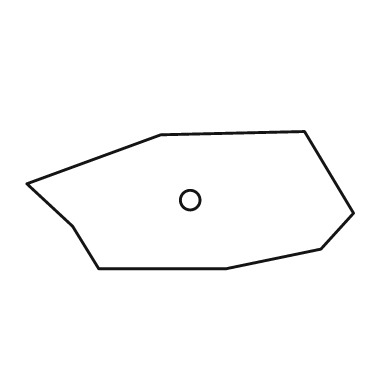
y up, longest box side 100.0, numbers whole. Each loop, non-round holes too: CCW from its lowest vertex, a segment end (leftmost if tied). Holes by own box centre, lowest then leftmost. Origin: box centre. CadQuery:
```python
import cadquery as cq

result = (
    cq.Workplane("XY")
    .moveTo(-28.0, -21.0)
    .lineTo(11.0, -21.0)
    .lineTo(40.0, -15.0)
    .lineTo(50.0, -4.0)
    .lineTo(35.0, 21.0)
    .lineTo(-9.0, 20.0)
    .lineTo(-50.0, 5.0)
    .lineTo(-36.0, -8.0)
    .close()
    .moveTo(0.0, 0.0)
    .circle(3.0)
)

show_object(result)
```